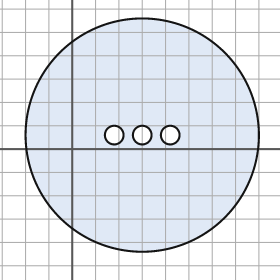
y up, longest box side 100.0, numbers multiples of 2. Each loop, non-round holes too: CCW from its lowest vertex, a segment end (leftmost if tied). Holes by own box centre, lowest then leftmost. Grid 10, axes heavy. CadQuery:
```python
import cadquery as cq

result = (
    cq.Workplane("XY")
    .moveTo(30.0, 6.0)
    .circle(50.0)
    .moveTo(18.0, 6.0)
    .circle(4.0)
    .moveTo(30.0, 6.0)
    .circle(4.0)
    .moveTo(42.0, 6.0)
    .circle(4.0)
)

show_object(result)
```